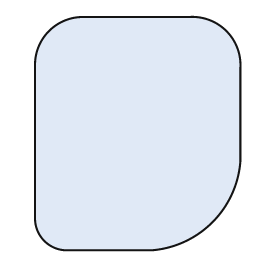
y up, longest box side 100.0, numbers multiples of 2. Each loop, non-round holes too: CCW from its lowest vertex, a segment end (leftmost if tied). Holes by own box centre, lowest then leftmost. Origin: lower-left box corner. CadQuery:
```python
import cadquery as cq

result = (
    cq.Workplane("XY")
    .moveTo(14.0, 0.0)
    .lineTo(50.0, 0.0)
    .threePointArc((76.0, 12.0), (88.0, 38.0))
    .lineTo(88.0, 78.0)
    .threePointArc((82.0, 94.0), (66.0, 100.0))
    .lineTo(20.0, 100.0)
    .threePointArc((6.0, 94.0), (0.0, 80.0))
    .lineTo(0.0, 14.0)
    .threePointArc((4.0, 4.0), (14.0, 0.0))
    .close()
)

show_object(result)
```